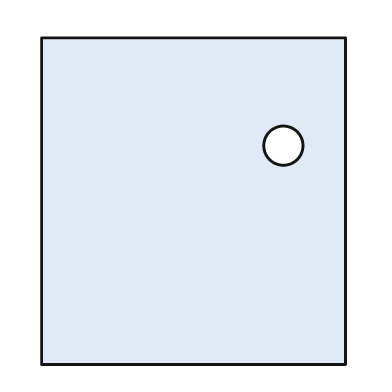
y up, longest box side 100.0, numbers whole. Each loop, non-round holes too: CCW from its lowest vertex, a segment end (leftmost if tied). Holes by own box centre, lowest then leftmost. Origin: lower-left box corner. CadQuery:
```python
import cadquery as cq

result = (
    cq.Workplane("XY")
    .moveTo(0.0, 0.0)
    .lineTo(93.0, 0.0)
    .lineTo(93.0, 100.0)
    .lineTo(0.0, 100.0)
    .close()
    .moveTo(74.0, 67.0)
    .circle(6.0)
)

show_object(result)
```